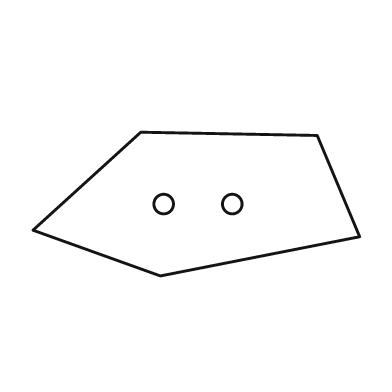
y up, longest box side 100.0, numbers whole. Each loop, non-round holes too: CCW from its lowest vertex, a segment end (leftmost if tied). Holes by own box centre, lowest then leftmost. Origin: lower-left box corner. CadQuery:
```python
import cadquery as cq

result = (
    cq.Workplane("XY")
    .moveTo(39.0, 0.0)
    .lineTo(100.0, 12.0)
    .lineTo(87.0, 43.0)
    .lineTo(33.0, 44.0)
    .lineTo(0.0, 14.0)
    .close()
    .moveTo(40.0, 22.0)
    .circle(3.0)
    .moveTo(61.0, 22.0)
    .circle(3.0)
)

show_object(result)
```